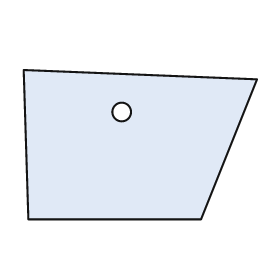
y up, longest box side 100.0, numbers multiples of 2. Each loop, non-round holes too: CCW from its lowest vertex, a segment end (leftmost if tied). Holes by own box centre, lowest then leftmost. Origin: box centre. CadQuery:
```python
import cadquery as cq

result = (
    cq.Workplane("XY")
    .moveTo(-48.0, -32.0)
    .lineTo(26.0, -32.0)
    .lineTo(50.0, 28.0)
    .lineTo(-50.0, 32.0)
    .close()
    .moveTo(-8.0, 14.0)
    .circle(4.0)
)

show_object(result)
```